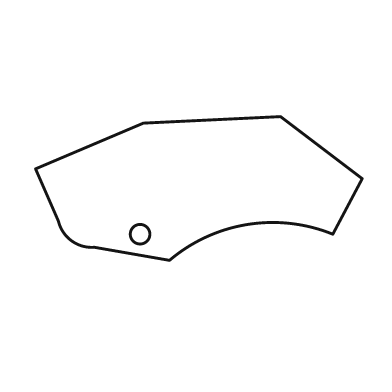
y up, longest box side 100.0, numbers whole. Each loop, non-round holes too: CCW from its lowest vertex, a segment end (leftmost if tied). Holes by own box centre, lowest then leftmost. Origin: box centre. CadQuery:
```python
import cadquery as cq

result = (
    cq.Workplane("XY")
    .moveTo(-9.0, -22.0)
    .threePointArc((15.0, -11.0), (41.0, -14.0))
    .lineTo(50.0, 3.0)
    .lineTo(25.0, 22.0)
    .lineTo(-17.0, 20.0)
    .lineTo(-50.0, 6.0)
    .lineTo(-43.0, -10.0)
    .threePointArc((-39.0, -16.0), (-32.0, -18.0))
    .close()
    .moveTo(-18.0, -14.0)
    .circle(3.0)
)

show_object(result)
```